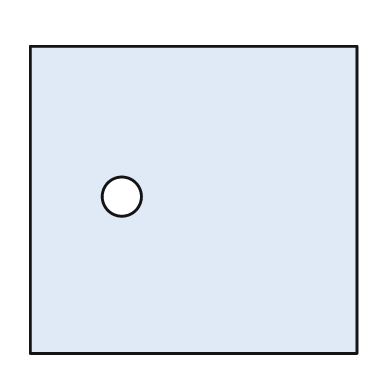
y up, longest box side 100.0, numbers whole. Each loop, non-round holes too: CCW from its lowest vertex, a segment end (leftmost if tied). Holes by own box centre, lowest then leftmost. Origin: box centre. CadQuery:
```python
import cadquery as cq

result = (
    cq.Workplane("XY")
    .moveTo(-50.0, -47.0)
    .lineTo(50.0, -47.0)
    .lineTo(50.0, 47.0)
    .lineTo(-50.0, 47.0)
    .close()
    .moveTo(-22.0, 1.0)
    .circle(6.0)
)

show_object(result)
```